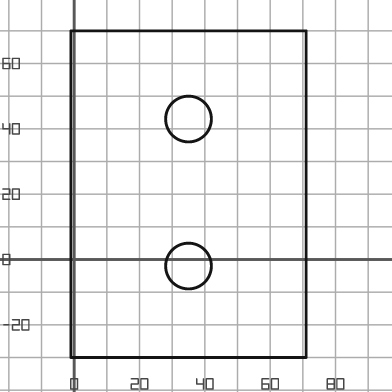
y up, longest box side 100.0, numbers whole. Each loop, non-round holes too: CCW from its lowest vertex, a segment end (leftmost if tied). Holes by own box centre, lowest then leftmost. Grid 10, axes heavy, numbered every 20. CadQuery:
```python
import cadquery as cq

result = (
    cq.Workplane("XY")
    .moveTo(-1.0, -30.0)
    .lineTo(71.0, -30.0)
    .lineTo(71.0, 70.0)
    .lineTo(-1.0, 70.0)
    .close()
    .moveTo(35.0, -2.0)
    .circle(7.0)
    .moveTo(35.0, 43.0)
    .circle(7.0)
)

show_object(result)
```